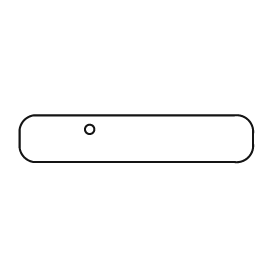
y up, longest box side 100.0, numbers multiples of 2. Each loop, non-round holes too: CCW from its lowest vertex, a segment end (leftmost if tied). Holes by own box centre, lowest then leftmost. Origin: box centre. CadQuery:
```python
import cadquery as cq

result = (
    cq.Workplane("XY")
    .moveTo(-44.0, -10.0)
    .lineTo(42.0, -10.0)
    .threePointArc((48.0, -8.0), (50.0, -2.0))
    .lineTo(50.0, 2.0)
    .threePointArc((48.0, 8.0), (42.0, 10.0))
    .lineTo(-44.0, 10.0)
    .threePointArc((-48.0, 8.0), (-50.0, 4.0))
    .lineTo(-50.0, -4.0)
    .threePointArc((-48.0, -8.0), (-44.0, -10.0))
    .close()
    .moveTo(-20.0, 4.0)
    .circle(2.0)
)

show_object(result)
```